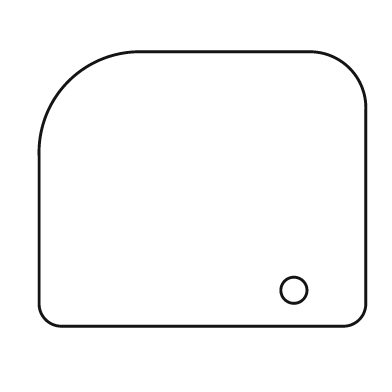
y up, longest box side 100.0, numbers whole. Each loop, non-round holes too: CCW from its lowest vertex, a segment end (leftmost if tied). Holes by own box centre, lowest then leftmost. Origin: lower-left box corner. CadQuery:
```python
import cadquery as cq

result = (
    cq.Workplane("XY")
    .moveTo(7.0, 0.0)
    .lineTo(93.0, 0.0)
    .threePointArc((98.0, 2.0), (100.0, 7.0))
    .lineTo(100.0, 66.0)
    .threePointArc((95.0, 79.0), (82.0, 84.0))
    .lineTo(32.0, 84.0)
    .threePointArc((9.0, 75.0), (0.0, 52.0))
    .lineTo(0.0, 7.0)
    .threePointArc((2.0, 2.0), (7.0, 0.0))
    .close()
    .moveTo(78.0, 11.0)
    .circle(4.0)
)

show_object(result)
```